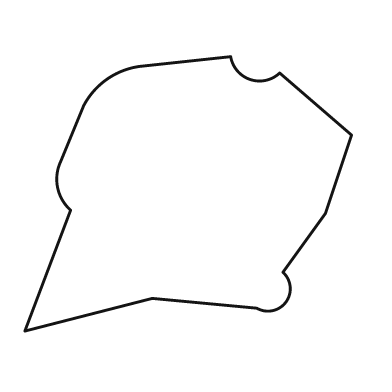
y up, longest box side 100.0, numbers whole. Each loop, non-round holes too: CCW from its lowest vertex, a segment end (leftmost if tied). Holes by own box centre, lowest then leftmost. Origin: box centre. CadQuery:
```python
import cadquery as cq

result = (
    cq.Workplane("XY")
    .moveTo(-50.0, -42.0)
    .lineTo(-11.0, -32.0)
    .lineTo(21.0, -35.0)
    .threePointArc((30.0, -33.0), (29.0, -24.0))
    .lineTo(42.0, -6.0)
    .lineTo(50.0, 18.0)
    .lineTo(28.0, 37.0)
    .threePointArc((19.0, 35.0), (13.0, 42.0))
    .lineTo(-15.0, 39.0)
    .threePointArc((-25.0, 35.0), (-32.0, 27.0))
    .lineTo(-39.0, 10.0)
    .threePointArc((-40.0, 2.0), (-36.0, -5.0))
    .close()
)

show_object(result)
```